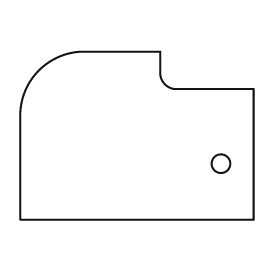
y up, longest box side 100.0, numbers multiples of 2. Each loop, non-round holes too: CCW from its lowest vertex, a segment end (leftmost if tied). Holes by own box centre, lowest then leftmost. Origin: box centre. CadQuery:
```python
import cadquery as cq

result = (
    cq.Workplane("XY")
    .moveTo(-50.0, -36.0)
    .lineTo(50.0, -36.0)
    .lineTo(50.0, 20.0)
    .lineTo(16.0, 20.0)
    .threePointArc((12.0, 22.0), (10.0, 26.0))
    .lineTo(10.0, 36.0)
    .lineTo(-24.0, 36.0)
    .threePointArc((-42.0, 28.0), (-50.0, 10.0))
    .close()
    .moveTo(36.0, -12.0)
    .circle(4.0)
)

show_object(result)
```